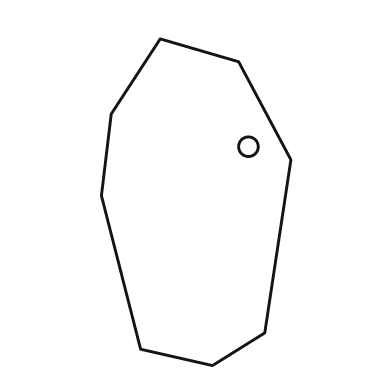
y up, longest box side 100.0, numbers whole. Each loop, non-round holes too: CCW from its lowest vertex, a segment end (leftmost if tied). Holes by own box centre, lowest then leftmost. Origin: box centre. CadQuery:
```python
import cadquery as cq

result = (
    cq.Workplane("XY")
    .moveTo(5.0, -50.0)
    .lineTo(21.0, -40.0)
    .lineTo(29.0, 13.0)
    .lineTo(13.0, 43.0)
    .lineTo(-11.0, 50.0)
    .lineTo(-26.0, 27.0)
    .lineTo(-29.0, 2.0)
    .lineTo(-17.0, -45.0)
    .close()
    .moveTo(16.0, 17.0)
    .circle(3.0)
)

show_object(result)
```